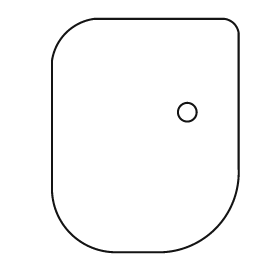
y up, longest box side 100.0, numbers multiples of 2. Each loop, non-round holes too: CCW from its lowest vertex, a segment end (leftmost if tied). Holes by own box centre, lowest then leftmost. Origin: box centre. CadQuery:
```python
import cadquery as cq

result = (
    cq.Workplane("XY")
    .moveTo(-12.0, -50.0)
    .lineTo(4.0, -50.0)
    .threePointArc((30.0, -40.0), (40.0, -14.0))
    .lineTo(40.0, 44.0)
    .threePointArc((38.0, 48.0), (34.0, 50.0))
    .lineTo(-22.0, 50.0)
    .threePointArc((-34.0, 44.0), (-40.0, 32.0))
    .lineTo(-40.0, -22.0)
    .threePointArc((-32.0, -42.0), (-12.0, -50.0))
    .close()
    .moveTo(18.0, 10.0)
    .circle(4.0)
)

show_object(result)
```